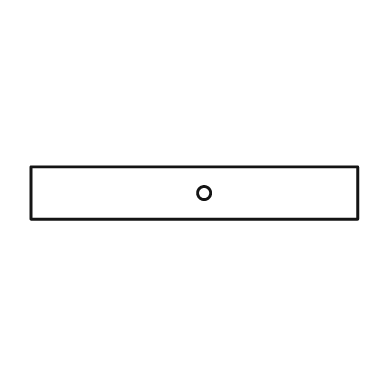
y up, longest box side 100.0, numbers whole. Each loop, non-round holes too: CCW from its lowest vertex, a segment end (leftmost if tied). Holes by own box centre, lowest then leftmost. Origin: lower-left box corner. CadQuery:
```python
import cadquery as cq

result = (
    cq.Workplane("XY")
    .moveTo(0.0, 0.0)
    .lineTo(100.0, 0.0)
    .lineTo(100.0, 16.0)
    .lineTo(0.0, 16.0)
    .close()
    .moveTo(53.0, 8.0)
    .circle(2.0)
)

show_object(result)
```